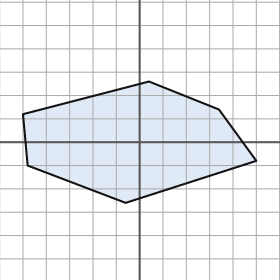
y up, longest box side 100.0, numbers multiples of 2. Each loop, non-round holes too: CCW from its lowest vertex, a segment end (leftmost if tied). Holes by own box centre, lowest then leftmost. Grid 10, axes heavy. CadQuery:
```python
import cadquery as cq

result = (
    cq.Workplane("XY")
    .moveTo(-6.0, -26.0)
    .lineTo(50.0, -8.0)
    .lineTo(34.0, 14.0)
    .lineTo(4.0, 26.0)
    .lineTo(-50.0, 12.0)
    .lineTo(-48.0, -10.0)
    .close()
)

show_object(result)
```